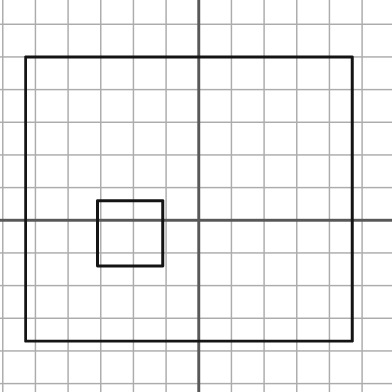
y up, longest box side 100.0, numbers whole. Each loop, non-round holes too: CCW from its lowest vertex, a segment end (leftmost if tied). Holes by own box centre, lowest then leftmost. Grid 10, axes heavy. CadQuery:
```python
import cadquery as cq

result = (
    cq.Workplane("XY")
    .moveTo(-53.0, -37.0)
    .lineTo(47.0, -37.0)
    .lineTo(47.0, 50.0)
    .lineTo(-53.0, 50.0)
    .close()
    .moveTo(-31.0, -14.0)
    .lineTo(-11.0, -14.0)
    .lineTo(-11.0, 6.0)
    .lineTo(-31.0, 6.0)
    .close()
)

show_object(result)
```